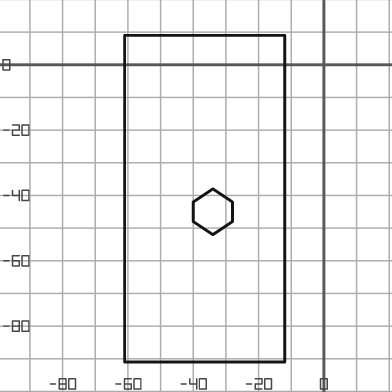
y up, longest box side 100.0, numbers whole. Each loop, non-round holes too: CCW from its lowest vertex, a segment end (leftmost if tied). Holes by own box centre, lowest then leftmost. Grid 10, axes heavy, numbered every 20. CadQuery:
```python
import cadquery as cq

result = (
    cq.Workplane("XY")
    .moveTo(-61.0, -91.0)
    .lineTo(-12.0, -91.0)
    .lineTo(-12.0, 9.0)
    .lineTo(-61.0, 9.0)
    .close()
    .moveTo(-34.0, -52.0)
    .lineTo(-28.0, -48.0)
    .lineTo(-28.0, -42.0)
    .lineTo(-34.0, -38.0)
    .lineTo(-40.0, -42.0)
    .lineTo(-40.0, -48.0)
    .close()
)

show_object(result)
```